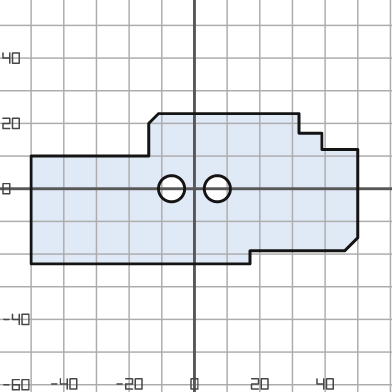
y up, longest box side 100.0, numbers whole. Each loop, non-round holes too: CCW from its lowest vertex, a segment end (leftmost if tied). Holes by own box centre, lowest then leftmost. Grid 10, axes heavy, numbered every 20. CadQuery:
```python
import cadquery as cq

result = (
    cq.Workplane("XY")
    .moveTo(-50.0, -23.0)
    .lineTo(17.0, -23.0)
    .lineTo(17.0, -19.0)
    .lineTo(46.0, -19.0)
    .lineTo(50.0, -15.0)
    .lineTo(50.0, 12.0)
    .lineTo(39.0, 12.0)
    .lineTo(39.0, 17.0)
    .lineTo(32.0, 17.0)
    .lineTo(32.0, 23.0)
    .lineTo(-11.0, 23.0)
    .lineTo(-14.0, 20.0)
    .lineTo(-14.0, 10.0)
    .lineTo(-50.0, 10.0)
    .close()
    .moveTo(-7.0, 0.0)
    .circle(4.0)
    .moveTo(7.0, 0.0)
    .circle(4.0)
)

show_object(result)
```